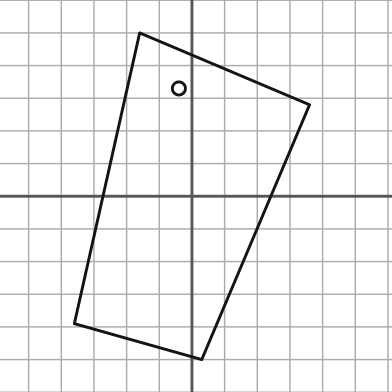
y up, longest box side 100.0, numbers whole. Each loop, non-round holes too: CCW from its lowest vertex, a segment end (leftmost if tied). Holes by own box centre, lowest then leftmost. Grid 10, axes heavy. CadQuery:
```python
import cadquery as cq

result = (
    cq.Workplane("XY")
    .moveTo(3.0, -50.0)
    .lineTo(36.0, 28.0)
    .lineTo(-16.0, 50.0)
    .lineTo(-36.0, -39.0)
    .close()
    .moveTo(-4.0, 33.0)
    .circle(2.0)
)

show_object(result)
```